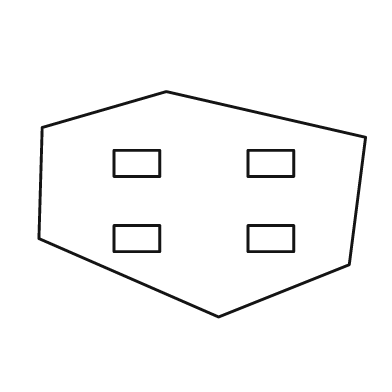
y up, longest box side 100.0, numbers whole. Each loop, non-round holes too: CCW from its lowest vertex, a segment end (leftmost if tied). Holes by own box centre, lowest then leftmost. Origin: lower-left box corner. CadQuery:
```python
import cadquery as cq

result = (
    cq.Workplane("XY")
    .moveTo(55.0, 0.0)
    .lineTo(95.0, 16.0)
    .lineTo(100.0, 55.0)
    .lineTo(39.0, 69.0)
    .lineTo(1.0, 58.0)
    .lineTo(0.0, 24.0)
    .close()
    .moveTo(23.0, 20.0)
    .lineTo(37.0, 20.0)
    .lineTo(37.0, 28.0)
    .lineTo(23.0, 28.0)
    .close()
    .moveTo(64.0, 20.0)
    .lineTo(78.0, 20.0)
    .lineTo(78.0, 28.0)
    .lineTo(64.0, 28.0)
    .close()
    .moveTo(23.0, 43.0)
    .lineTo(37.0, 43.0)
    .lineTo(37.0, 51.0)
    .lineTo(23.0, 51.0)
    .close()
    .moveTo(64.0, 43.0)
    .lineTo(78.0, 43.0)
    .lineTo(78.0, 51.0)
    .lineTo(64.0, 51.0)
    .close()
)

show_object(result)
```